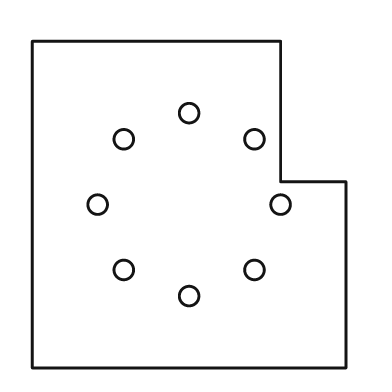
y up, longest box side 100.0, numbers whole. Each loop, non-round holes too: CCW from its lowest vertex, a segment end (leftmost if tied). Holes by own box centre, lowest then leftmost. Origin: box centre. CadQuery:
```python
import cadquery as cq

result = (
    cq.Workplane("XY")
    .moveTo(-48.0, -50.0)
    .lineTo(48.0, -50.0)
    .lineTo(48.0, 7.0)
    .lineTo(28.0, 7.0)
    .lineTo(28.0, 50.0)
    .lineTo(-48.0, 50.0)
    .close()
    .moveTo(0.0, -28.0)
    .circle(3.0)
    .moveTo(-20.0, -20.0)
    .circle(3.0)
    .moveTo(20.0, -20.0)
    .circle(3.0)
    .moveTo(-28.0, 0.0)
    .circle(3.0)
    .moveTo(28.0, 0.0)
    .circle(3.0)
    .moveTo(-20.0, 20.0)
    .circle(3.0)
    .moveTo(20.0, 20.0)
    .circle(3.0)
    .moveTo(0.0, 28.0)
    .circle(3.0)
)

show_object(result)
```